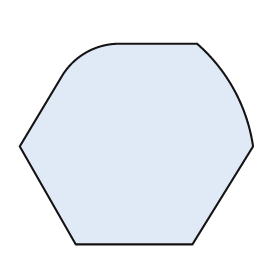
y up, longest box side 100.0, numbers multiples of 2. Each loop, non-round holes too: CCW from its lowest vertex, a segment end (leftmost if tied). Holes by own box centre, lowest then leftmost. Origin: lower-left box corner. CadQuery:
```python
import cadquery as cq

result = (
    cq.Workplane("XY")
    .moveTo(24.0, 0.0)
    .lineTo(74.0, 0.0)
    .lineTo(100.0, 42.0)
    .threePointArc((92.0, 66.0), (76.0, 86.0))
    .lineTo(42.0, 86.0)
    .threePointArc((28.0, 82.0), (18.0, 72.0))
    .lineTo(0.0, 42.0)
    .close()
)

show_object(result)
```